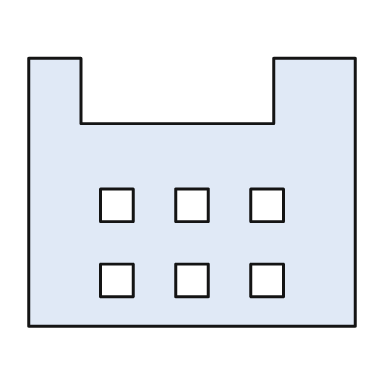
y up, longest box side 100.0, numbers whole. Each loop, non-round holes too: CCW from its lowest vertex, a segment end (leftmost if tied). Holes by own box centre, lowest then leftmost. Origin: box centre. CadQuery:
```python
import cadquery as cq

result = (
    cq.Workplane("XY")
    .moveTo(-50.0, -41.0)
    .lineTo(50.0, -41.0)
    .lineTo(50.0, 41.0)
    .lineTo(25.0, 41.0)
    .lineTo(25.0, 21.0)
    .lineTo(-34.0, 21.0)
    .lineTo(-34.0, 41.0)
    .lineTo(-50.0, 41.0)
    .close()
    .moveTo(-28.0, -32.0)
    .lineTo(-18.0, -32.0)
    .lineTo(-18.0, -22.0)
    .lineTo(-28.0, -22.0)
    .close()
    .moveTo(-5.0, -32.0)
    .lineTo(5.0, -32.0)
    .lineTo(5.0, -22.0)
    .lineTo(-5.0, -22.0)
    .close()
    .moveTo(18.0, -32.0)
    .lineTo(28.0, -32.0)
    .lineTo(28.0, -22.0)
    .lineTo(18.0, -22.0)
    .close()
    .moveTo(-28.0, -9.0)
    .lineTo(-18.0, -9.0)
    .lineTo(-18.0, 1.0)
    .lineTo(-28.0, 1.0)
    .close()
    .moveTo(-5.0, -9.0)
    .lineTo(5.0, -9.0)
    .lineTo(5.0, 1.0)
    .lineTo(-5.0, 1.0)
    .close()
    .moveTo(18.0, -9.0)
    .lineTo(28.0, -9.0)
    .lineTo(28.0, 1.0)
    .lineTo(18.0, 1.0)
    .close()
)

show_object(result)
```